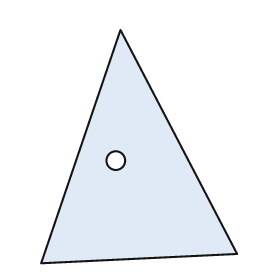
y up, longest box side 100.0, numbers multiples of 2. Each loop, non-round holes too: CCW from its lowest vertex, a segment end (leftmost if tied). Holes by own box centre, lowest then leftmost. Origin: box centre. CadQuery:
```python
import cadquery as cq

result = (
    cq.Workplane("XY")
    .moveTo(-42.0, -50.0)
    .lineTo(42.0, -46.0)
    .lineTo(-8.0, 50.0)
    .close()
    .moveTo(-10.0, -6.0)
    .circle(4.0)
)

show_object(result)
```